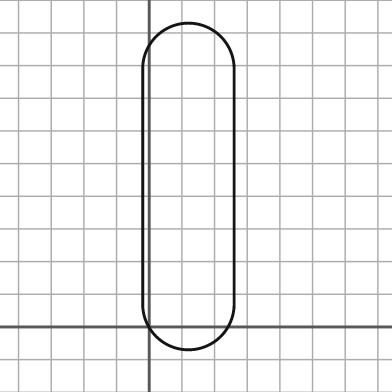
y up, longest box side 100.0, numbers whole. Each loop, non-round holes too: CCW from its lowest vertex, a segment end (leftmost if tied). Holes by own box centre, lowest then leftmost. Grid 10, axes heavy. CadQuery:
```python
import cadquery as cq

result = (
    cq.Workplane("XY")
    .moveTo(-2.0, 7.0)
    .threePointArc((12.0, -7.0), (26.0, 7.0))
    .lineTo(26.0, 79.0)
    .threePointArc((12.0, 93.0), (-2.0, 79.0))
    .close()
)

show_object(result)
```